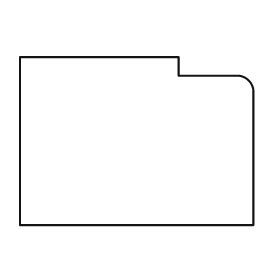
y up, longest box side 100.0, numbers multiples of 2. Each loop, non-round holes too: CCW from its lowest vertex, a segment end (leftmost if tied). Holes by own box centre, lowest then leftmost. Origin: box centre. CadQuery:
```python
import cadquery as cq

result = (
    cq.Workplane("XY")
    .moveTo(-50.0, -36.0)
    .lineTo(50.0, -36.0)
    .lineTo(50.0, 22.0)
    .threePointArc((48.0, 26.0), (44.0, 28.0))
    .lineTo(18.0, 28.0)
    .lineTo(18.0, 36.0)
    .lineTo(-50.0, 36.0)
    .close()
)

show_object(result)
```